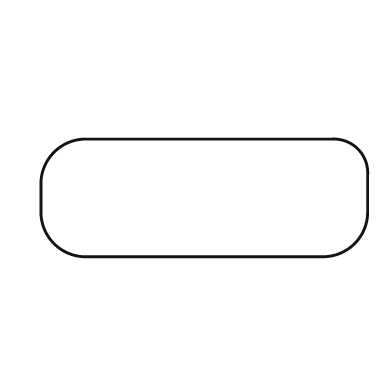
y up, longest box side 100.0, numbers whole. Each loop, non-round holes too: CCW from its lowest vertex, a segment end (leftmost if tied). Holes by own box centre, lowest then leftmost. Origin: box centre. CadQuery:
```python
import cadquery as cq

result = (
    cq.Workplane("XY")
    .moveTo(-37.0, -18.0)
    .lineTo(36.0, -18.0)
    .threePointArc((46.0, -14.0), (50.0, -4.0))
    .lineTo(50.0, 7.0)
    .threePointArc((47.0, 15.0), (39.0, 18.0))
    .lineTo(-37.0, 18.0)
    .threePointArc((-46.0, 14.0), (-50.0, 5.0))
    .lineTo(-50.0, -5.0)
    .threePointArc((-46.0, -14.0), (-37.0, -18.0))
    .close()
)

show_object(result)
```